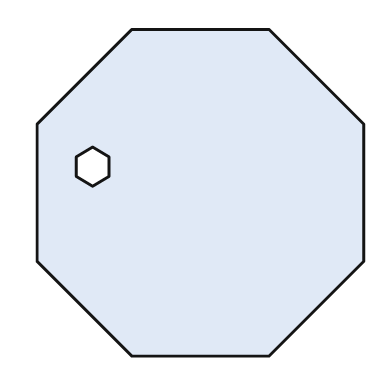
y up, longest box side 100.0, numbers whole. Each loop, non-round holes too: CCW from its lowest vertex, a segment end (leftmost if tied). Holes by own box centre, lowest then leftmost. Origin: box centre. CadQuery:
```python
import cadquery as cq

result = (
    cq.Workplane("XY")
    .moveTo(-21.0, -50.0)
    .lineTo(21.0, -50.0)
    .lineTo(50.0, -21.0)
    .lineTo(50.0, 21.0)
    .lineTo(21.0, 50.0)
    .lineTo(-21.0, 50.0)
    .lineTo(-50.0, 21.0)
    .lineTo(-50.0, -21.0)
    .close()
    .moveTo(-33.0, 2.0)
    .lineTo(-28.0, 5.0)
    .lineTo(-28.0, 11.0)
    .lineTo(-33.0, 14.0)
    .lineTo(-38.0, 11.0)
    .lineTo(-38.0, 5.0)
    .close()
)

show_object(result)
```